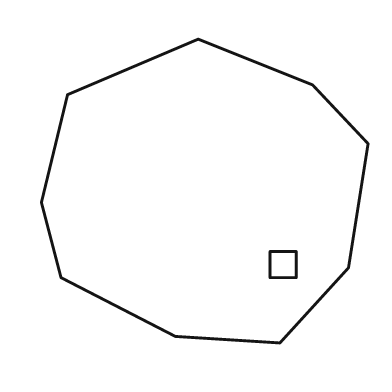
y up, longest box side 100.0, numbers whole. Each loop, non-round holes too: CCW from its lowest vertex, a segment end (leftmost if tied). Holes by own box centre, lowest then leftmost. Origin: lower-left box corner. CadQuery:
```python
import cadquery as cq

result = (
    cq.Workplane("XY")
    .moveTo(73.0, 0.0)
    .lineTo(94.0, 23.0)
    .lineTo(100.0, 61.0)
    .lineTo(83.0, 79.0)
    .lineTo(48.0, 93.0)
    .lineTo(8.0, 76.0)
    .lineTo(0.0, 43.0)
    .lineTo(6.0, 20.0)
    .lineTo(41.0, 2.0)
    .close()
    .moveTo(70.0, 20.0)
    .lineTo(78.0, 20.0)
    .lineTo(78.0, 28.0)
    .lineTo(70.0, 28.0)
    .close()
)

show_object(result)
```